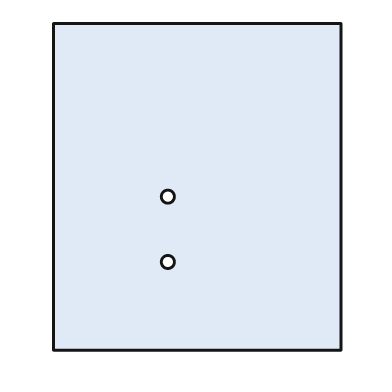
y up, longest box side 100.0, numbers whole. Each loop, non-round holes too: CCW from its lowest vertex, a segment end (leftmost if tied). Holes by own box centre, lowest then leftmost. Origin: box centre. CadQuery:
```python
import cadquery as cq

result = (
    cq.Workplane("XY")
    .moveTo(-44.0, -50.0)
    .lineTo(44.0, -50.0)
    .lineTo(44.0, 50.0)
    .lineTo(-44.0, 50.0)
    .close()
    .moveTo(-9.0, -23.0)
    .circle(2.0)
    .moveTo(-9.0, -3.0)
    .circle(2.0)
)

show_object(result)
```